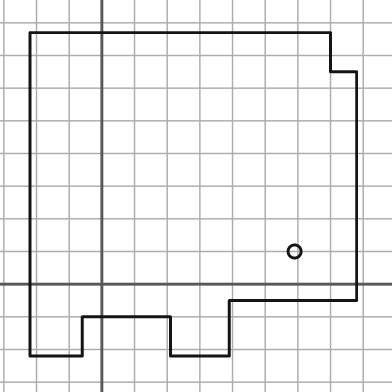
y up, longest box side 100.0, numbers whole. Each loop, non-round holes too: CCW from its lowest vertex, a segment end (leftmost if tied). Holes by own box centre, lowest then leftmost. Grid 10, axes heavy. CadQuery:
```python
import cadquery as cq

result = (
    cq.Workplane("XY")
    .moveTo(-22.0, -22.0)
    .lineTo(-6.0, -22.0)
    .lineTo(-6.0, -10.0)
    .lineTo(21.0, -10.0)
    .lineTo(21.0, -22.0)
    .lineTo(39.0, -22.0)
    .lineTo(39.0, -5.0)
    .lineTo(78.0, -5.0)
    .lineTo(78.0, 65.0)
    .lineTo(70.0, 65.0)
    .lineTo(70.0, 77.0)
    .lineTo(-22.0, 77.0)
    .close()
    .moveTo(59.0, 10.0)
    .circle(2.0)
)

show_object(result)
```